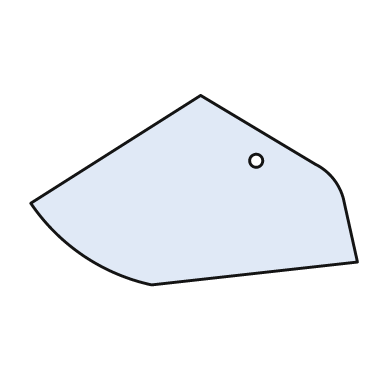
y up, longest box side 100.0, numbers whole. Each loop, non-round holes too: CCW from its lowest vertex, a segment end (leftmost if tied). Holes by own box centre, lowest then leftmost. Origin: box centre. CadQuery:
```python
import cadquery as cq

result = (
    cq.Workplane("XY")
    .moveTo(-13.0, -29.0)
    .lineTo(50.0, -22.0)
    .lineTo(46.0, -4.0)
    .threePointArc((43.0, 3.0), (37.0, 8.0))
    .lineTo(2.0, 29.0)
    .lineTo(-50.0, -4.0)
    .threePointArc((-34.0, -20.0), (-13.0, -29.0))
    .close()
    .moveTo(19.0, 9.0)
    .circle(2.0)
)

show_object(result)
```